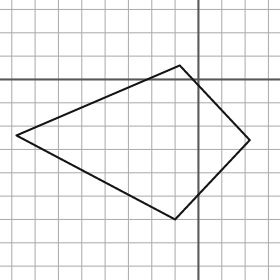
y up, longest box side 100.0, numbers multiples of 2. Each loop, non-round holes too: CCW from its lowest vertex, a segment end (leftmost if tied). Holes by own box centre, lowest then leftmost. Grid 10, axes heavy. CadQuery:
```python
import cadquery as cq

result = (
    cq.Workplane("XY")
    .moveTo(-10.0, -60.0)
    .lineTo(22.0, -26.0)
    .lineTo(-8.0, 6.0)
    .lineTo(-78.0, -24.0)
    .close()
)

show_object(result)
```